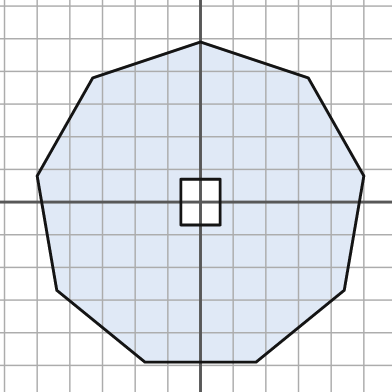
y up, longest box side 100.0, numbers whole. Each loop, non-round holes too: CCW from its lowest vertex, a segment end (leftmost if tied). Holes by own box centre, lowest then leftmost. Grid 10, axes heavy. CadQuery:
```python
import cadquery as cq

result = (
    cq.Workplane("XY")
    .moveTo(-17.0, -49.0)
    .lineTo(17.0, -49.0)
    .lineTo(44.0, -27.0)
    .lineTo(50.0, 8.0)
    .lineTo(33.0, 38.0)
    .lineTo(0.0, 49.0)
    .lineTo(-33.0, 38.0)
    .lineTo(-50.0, 8.0)
    .lineTo(-44.0, -27.0)
    .close()
    .moveTo(-6.0, -7.0)
    .lineTo(6.0, -7.0)
    .lineTo(6.0, 7.0)
    .lineTo(-6.0, 7.0)
    .close()
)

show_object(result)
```